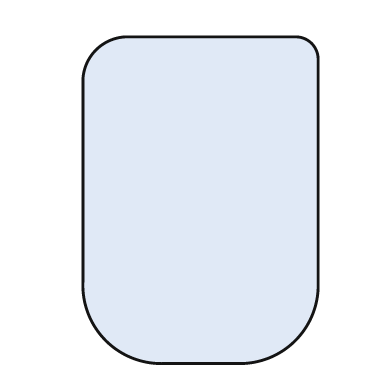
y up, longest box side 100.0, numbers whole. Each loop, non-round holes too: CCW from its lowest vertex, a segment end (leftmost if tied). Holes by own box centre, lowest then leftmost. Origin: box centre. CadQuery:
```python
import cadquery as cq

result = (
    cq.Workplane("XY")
    .moveTo(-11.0, -50.0)
    .lineTo(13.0, -50.0)
    .threePointArc((29.0, -43.0), (36.0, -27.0))
    .lineTo(36.0, 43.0)
    .threePointArc((34.0, 48.0), (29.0, 50.0))
    .lineTo(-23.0, 50.0)
    .threePointArc((-32.0, 46.0), (-36.0, 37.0))
    .lineTo(-36.0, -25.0)
    .threePointArc((-29.0, -43.0), (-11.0, -50.0))
    .close()
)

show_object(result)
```